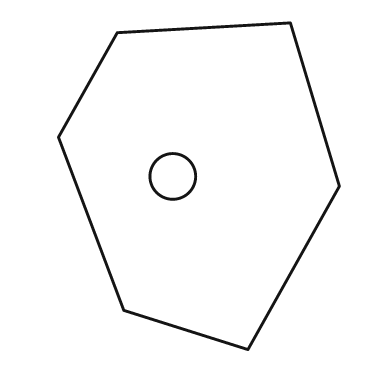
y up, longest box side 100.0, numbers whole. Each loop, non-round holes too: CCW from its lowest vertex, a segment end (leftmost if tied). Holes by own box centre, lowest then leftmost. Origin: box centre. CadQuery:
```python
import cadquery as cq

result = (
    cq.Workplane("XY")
    .moveTo(15.0, -50.0)
    .lineTo(43.0, 0.0)
    .lineTo(28.0, 50.0)
    .lineTo(-25.0, 47.0)
    .lineTo(-43.0, 15.0)
    .lineTo(-23.0, -38.0)
    .close()
    .moveTo(-8.0, 3.0)
    .circle(7.0)
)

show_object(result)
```